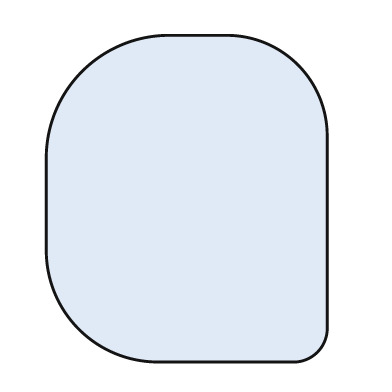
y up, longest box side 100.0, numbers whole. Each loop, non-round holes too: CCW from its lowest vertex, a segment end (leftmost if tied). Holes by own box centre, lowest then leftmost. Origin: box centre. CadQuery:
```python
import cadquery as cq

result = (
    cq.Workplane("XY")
    .moveTo(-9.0, -50.0)
    .lineTo(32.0, -50.0)
    .threePointArc((40.0, -47.0), (43.0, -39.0))
    .lineTo(43.0, 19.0)
    .threePointArc((34.0, 41.0), (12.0, 50.0))
    .lineTo(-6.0, 50.0)
    .threePointArc((-32.0, 39.0), (-43.0, 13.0))
    .lineTo(-43.0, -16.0)
    .threePointArc((-33.0, -40.0), (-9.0, -50.0))
    .close()
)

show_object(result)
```